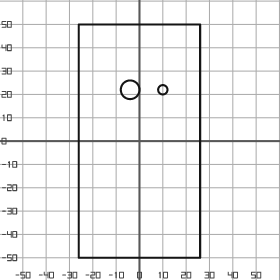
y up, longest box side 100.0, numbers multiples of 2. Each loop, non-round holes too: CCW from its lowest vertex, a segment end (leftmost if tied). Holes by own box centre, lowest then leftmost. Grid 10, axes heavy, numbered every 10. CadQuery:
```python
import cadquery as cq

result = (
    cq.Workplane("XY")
    .moveTo(-26.0, -50.0)
    .lineTo(26.0, -50.0)
    .lineTo(26.0, 50.0)
    .lineTo(-26.0, 50.0)
    .close()
    .moveTo(-4.0, 22.0)
    .circle(4.0)
    .moveTo(10.0, 22.0)
    .circle(2.0)
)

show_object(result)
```